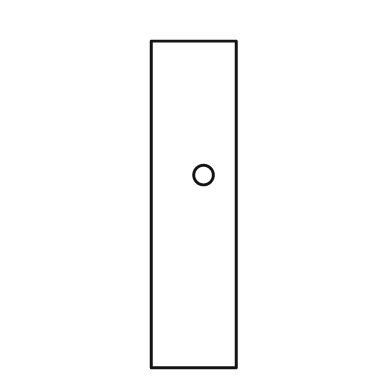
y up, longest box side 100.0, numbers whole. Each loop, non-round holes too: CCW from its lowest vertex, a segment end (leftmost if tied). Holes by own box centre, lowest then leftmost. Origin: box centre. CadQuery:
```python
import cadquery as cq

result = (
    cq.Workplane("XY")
    .moveTo(-13.0, -50.0)
    .lineTo(13.0, -50.0)
    .lineTo(13.0, 50.0)
    .lineTo(-13.0, 50.0)
    .close()
    .moveTo(3.0, 9.0)
    .circle(3.0)
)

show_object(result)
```